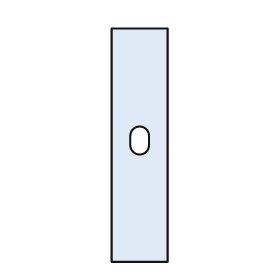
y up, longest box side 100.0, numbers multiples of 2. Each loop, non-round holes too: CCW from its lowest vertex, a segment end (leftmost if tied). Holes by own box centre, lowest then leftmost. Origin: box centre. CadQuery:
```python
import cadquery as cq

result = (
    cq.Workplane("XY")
    .moveTo(-12.0, -50.0)
    .lineTo(12.0, -50.0)
    .lineTo(12.0, 50.0)
    .lineTo(-12.0, 50.0)
    .close()
    .moveTo(-4.0, 0.0)
    .threePointArc((0.0, -4.0), (4.0, 0.0))
    .lineTo(4.0, 4.0)
    .threePointArc((0.0, 8.0), (-4.0, 4.0))
    .close()
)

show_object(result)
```